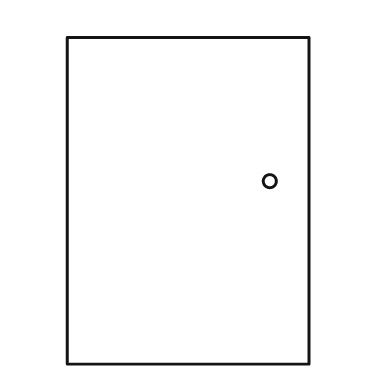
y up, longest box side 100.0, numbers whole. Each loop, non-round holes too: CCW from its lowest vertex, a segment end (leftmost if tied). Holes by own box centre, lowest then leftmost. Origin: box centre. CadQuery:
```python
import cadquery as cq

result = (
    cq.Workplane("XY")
    .moveTo(-37.0, -50.0)
    .lineTo(37.0, -50.0)
    .lineTo(37.0, 50.0)
    .lineTo(-37.0, 50.0)
    .close()
    .moveTo(25.0, 6.0)
    .circle(2.0)
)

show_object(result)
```